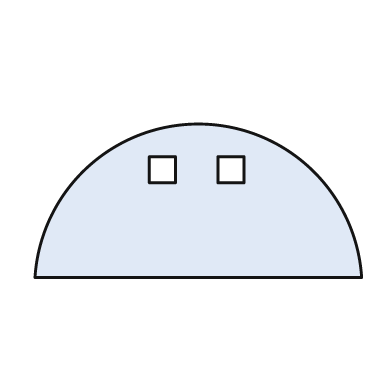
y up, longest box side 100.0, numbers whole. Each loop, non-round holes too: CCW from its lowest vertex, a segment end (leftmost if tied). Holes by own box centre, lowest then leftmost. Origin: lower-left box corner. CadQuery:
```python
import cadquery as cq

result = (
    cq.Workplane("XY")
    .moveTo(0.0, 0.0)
    .lineTo(100.0, 0.0)
    .threePointArc((50.0, 47.0), (0.0, 0.0))
    .close()
    .moveTo(35.0, 29.0)
    .lineTo(43.0, 29.0)
    .lineTo(43.0, 37.0)
    .lineTo(35.0, 37.0)
    .close()
    .moveTo(56.0, 29.0)
    .lineTo(64.0, 29.0)
    .lineTo(64.0, 37.0)
    .lineTo(56.0, 37.0)
    .close()
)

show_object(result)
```